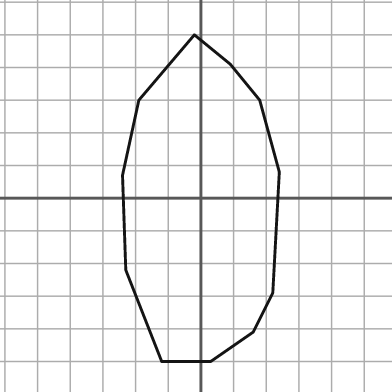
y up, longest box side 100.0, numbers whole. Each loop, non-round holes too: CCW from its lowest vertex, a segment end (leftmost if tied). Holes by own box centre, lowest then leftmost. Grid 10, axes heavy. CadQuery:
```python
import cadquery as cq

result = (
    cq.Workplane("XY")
    .moveTo(-12.0, -50.0)
    .lineTo(3.0, -50.0)
    .lineTo(16.0, -41.0)
    .lineTo(22.0, -29.0)
    .lineTo(24.0, 8.0)
    .lineTo(18.0, 30.0)
    .lineTo(9.0, 41.0)
    .lineTo(-2.0, 50.0)
    .lineTo(-19.0, 30.0)
    .lineTo(-24.0, 7.0)
    .lineTo(-23.0, -22.0)
    .close()
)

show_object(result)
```